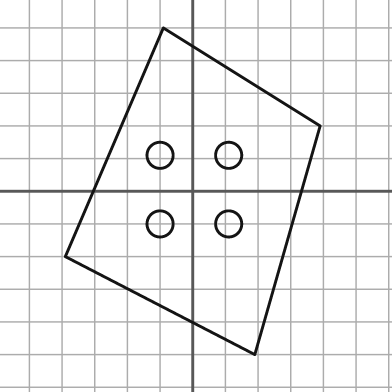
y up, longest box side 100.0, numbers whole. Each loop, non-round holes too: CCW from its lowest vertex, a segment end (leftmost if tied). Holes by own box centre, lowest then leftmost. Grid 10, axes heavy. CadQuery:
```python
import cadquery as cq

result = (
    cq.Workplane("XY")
    .moveTo(19.0, -50.0)
    .lineTo(39.0, 20.0)
    .lineTo(-9.0, 50.0)
    .lineTo(-39.0, -20.0)
    .close()
    .moveTo(-10.0, -10.0)
    .circle(4.0)
    .moveTo(11.0, -10.0)
    .circle(4.0)
    .moveTo(-10.0, 11.0)
    .circle(4.0)
    .moveTo(11.0, 11.0)
    .circle(4.0)
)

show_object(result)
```